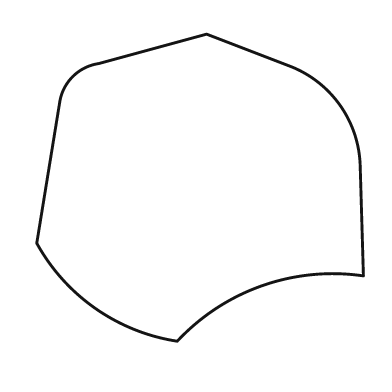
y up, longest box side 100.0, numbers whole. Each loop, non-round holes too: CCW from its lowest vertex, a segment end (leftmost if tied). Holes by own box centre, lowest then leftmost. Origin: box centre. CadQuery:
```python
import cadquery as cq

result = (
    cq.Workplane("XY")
    .moveTo(-7.0, -47.0)
    .threePointArc((19.0, -30.0), (50.0, -27.0))
    .lineTo(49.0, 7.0)
    .threePointArc((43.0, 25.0), (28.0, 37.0))
    .lineTo(2.0, 47.0)
    .lineTo(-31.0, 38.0)
    .threePointArc((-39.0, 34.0), (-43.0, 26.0))
    .lineTo(-50.0, -17.0)
    .threePointArc((-32.0, -37.0), (-7.0, -47.0))
    .close()
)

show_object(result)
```